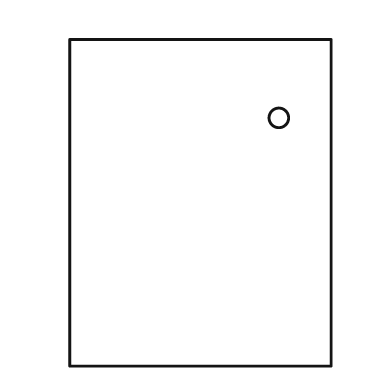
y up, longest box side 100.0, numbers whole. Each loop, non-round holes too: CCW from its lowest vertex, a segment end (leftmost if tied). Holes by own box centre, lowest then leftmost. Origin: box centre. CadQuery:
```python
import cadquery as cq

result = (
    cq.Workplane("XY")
    .moveTo(-40.0, -50.0)
    .lineTo(40.0, -50.0)
    .lineTo(40.0, 50.0)
    .lineTo(-40.0, 50.0)
    .close()
    .moveTo(24.0, 26.0)
    .circle(3.0)
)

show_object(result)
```